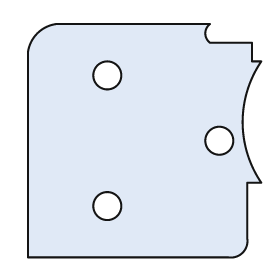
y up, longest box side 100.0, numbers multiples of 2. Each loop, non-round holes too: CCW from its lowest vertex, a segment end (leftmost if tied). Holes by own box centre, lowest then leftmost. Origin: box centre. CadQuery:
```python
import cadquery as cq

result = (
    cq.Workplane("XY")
    .moveTo(-50.0, -50.0)
    .lineTo(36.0, -50.0)
    .threePointArc((42.0, -48.0), (44.0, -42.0))
    .lineTo(44.0, -18.0)
    .lineTo(50.0, -18.0)
    .threePointArc((42.0, 8.0), (50.0, 34.0))
    .lineTo(46.0, 34.0)
    .lineTo(46.0, 42.0)
    .lineTo(28.0, 42.0)
    .threePointArc((26.0, 46.0), (28.0, 50.0))
    .lineTo(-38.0, 50.0)
    .threePointArc((-46.0, 46.0), (-50.0, 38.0))
    .close()
    .moveTo(-16.0, -28.0)
    .circle(6.0)
    .moveTo(32.0, 0.0)
    .circle(6.0)
    .moveTo(-16.0, 28.0)
    .circle(6.0)
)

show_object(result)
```